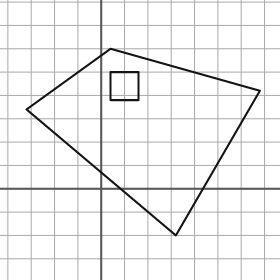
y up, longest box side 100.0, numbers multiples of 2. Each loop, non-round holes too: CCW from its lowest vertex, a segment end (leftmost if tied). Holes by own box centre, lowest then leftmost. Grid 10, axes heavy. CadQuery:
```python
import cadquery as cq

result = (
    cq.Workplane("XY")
    .moveTo(32.0, -20.0)
    .lineTo(68.0, 42.0)
    .lineTo(4.0, 60.0)
    .lineTo(-32.0, 34.0)
    .close()
    .moveTo(4.0, 38.0)
    .lineTo(16.0, 38.0)
    .lineTo(16.0, 50.0)
    .lineTo(4.0, 50.0)
    .close()
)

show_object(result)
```